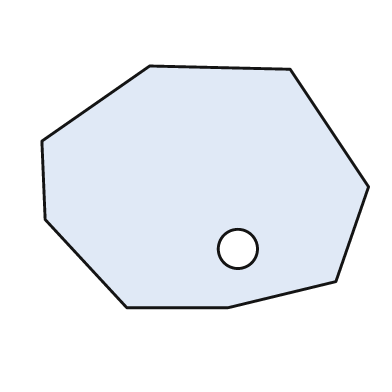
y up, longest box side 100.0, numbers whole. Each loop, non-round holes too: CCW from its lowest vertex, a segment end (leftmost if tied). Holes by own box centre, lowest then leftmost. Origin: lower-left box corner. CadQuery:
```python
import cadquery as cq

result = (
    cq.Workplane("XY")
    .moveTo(26.0, 0.0)
    .lineTo(57.0, 0.0)
    .lineTo(90.0, 8.0)
    .lineTo(100.0, 37.0)
    .lineTo(76.0, 73.0)
    .lineTo(33.0, 74.0)
    .lineTo(0.0, 51.0)
    .lineTo(1.0, 27.0)
    .close()
    .moveTo(60.0, 18.0)
    .circle(6.0)
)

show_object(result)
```